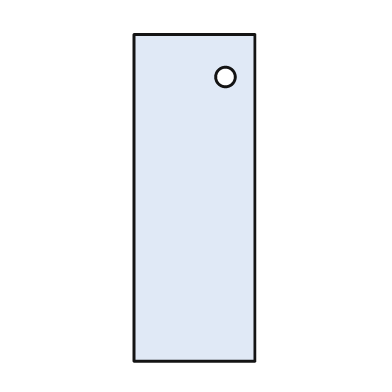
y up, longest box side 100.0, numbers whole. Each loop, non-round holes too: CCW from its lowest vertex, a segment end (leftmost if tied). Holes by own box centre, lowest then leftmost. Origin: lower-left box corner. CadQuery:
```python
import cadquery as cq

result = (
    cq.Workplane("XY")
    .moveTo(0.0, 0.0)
    .lineTo(37.0, 0.0)
    .lineTo(37.0, 100.0)
    .lineTo(0.0, 100.0)
    .close()
    .moveTo(28.0, 87.0)
    .circle(3.0)
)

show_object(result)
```